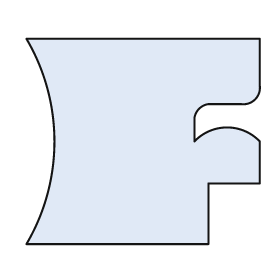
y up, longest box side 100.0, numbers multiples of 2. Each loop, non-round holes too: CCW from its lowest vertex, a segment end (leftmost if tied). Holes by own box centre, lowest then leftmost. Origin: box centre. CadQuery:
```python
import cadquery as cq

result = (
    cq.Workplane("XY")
    .moveTo(-50.0, -44.0)
    .lineTo(28.0, -44.0)
    .lineTo(28.0, -18.0)
    .lineTo(50.0, -18.0)
    .lineTo(50.0, 0.0)
    .threePointArc((36.0, 6.0), (22.0, 0.0))
    .lineTo(22.0, 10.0)
    .threePointArc((24.0, 14.0), (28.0, 16.0))
    .lineTo(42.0, 16.0)
    .threePointArc((48.0, 18.0), (50.0, 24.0))
    .lineTo(50.0, 44.0)
    .lineTo(-50.0, 44.0)
    .threePointArc((-38.0, 0.0), (-50.0, -44.0))
    .close()
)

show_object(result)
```